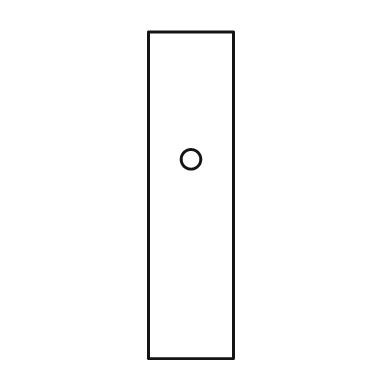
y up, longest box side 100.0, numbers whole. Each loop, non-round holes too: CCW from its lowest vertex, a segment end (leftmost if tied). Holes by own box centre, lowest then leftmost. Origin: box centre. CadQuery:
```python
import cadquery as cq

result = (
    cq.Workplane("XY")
    .moveTo(-13.0, -50.0)
    .lineTo(13.0, -50.0)
    .lineTo(13.0, 50.0)
    .lineTo(-13.0, 50.0)
    .close()
    .moveTo(0.0, 11.0)
    .circle(3.0)
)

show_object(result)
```